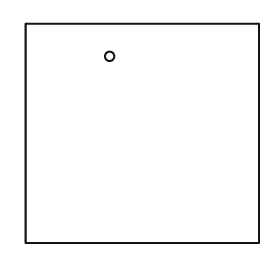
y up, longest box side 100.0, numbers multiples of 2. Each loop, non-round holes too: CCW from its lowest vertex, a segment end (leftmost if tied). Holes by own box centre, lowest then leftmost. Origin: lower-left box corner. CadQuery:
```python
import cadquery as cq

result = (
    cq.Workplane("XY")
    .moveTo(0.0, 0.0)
    .lineTo(100.0, 0.0)
    .lineTo(100.0, 94.0)
    .lineTo(0.0, 94.0)
    .close()
    .moveTo(36.0, 80.0)
    .circle(2.0)
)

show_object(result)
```